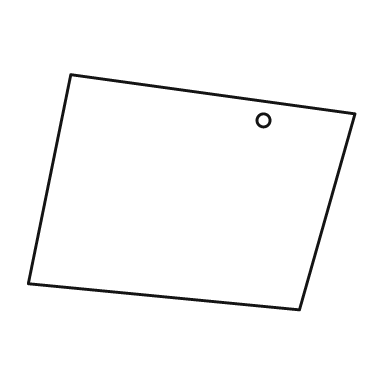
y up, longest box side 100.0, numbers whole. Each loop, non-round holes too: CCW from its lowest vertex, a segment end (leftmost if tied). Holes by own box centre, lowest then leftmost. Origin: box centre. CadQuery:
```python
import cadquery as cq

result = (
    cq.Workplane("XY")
    .moveTo(33.0, -36.0)
    .lineTo(50.0, 24.0)
    .lineTo(-37.0, 36.0)
    .lineTo(-50.0, -28.0)
    .close()
    .moveTo(22.0, 22.0)
    .circle(2.0)
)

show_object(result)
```